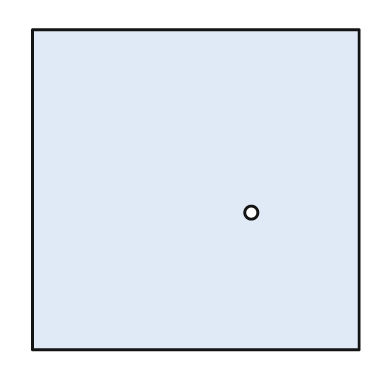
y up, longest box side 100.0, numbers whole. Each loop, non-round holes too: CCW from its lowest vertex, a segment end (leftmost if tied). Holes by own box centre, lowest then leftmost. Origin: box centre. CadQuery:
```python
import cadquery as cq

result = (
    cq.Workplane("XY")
    .moveTo(-50.0, -49.0)
    .lineTo(50.0, -49.0)
    .lineTo(50.0, 49.0)
    .lineTo(-50.0, 49.0)
    .close()
    .moveTo(17.0, -7.0)
    .circle(2.0)
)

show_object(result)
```